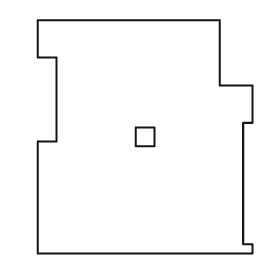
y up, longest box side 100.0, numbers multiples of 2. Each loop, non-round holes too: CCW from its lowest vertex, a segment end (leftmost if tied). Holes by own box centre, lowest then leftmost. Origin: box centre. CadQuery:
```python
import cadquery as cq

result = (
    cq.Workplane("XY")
    .moveTo(-46.0, -50.0)
    .lineTo(46.0, -50.0)
    .lineTo(46.0, -46.0)
    .lineTo(42.0, -46.0)
    .lineTo(42.0, 6.0)
    .lineTo(46.0, 6.0)
    .lineTo(46.0, 22.0)
    .lineTo(32.0, 22.0)
    .lineTo(32.0, 50.0)
    .lineTo(-46.0, 50.0)
    .lineTo(-46.0, 34.0)
    .lineTo(-38.0, 34.0)
    .lineTo(-38.0, -2.0)
    .lineTo(-46.0, -2.0)
    .close()
    .moveTo(-4.0, -4.0)
    .lineTo(4.0, -4.0)
    .lineTo(4.0, 4.0)
    .lineTo(-4.0, 4.0)
    .close()
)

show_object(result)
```